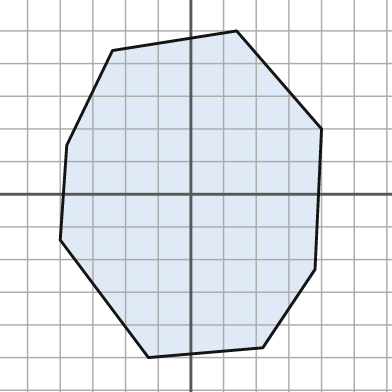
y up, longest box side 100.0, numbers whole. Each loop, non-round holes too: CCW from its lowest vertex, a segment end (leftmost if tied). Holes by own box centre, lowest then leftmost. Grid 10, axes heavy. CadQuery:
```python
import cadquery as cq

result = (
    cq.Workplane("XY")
    .moveTo(-13.0, -50.0)
    .lineTo(22.0, -47.0)
    .lineTo(38.0, -23.0)
    .lineTo(40.0, 20.0)
    .lineTo(14.0, 50.0)
    .lineTo(-24.0, 44.0)
    .lineTo(-38.0, 15.0)
    .lineTo(-40.0, -14.0)
    .close()
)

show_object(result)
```